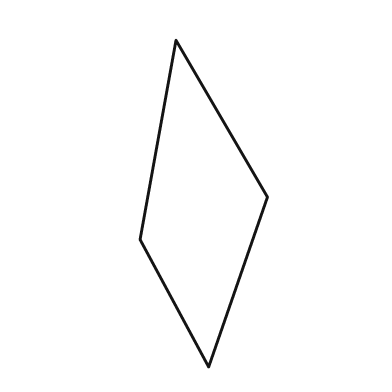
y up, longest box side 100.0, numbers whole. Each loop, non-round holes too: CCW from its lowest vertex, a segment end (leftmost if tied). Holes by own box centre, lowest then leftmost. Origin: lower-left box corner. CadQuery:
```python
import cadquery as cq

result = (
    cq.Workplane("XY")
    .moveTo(21.0, 0.0)
    .lineTo(39.0, 52.0)
    .lineTo(11.0, 100.0)
    .lineTo(0.0, 39.0)
    .close()
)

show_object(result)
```